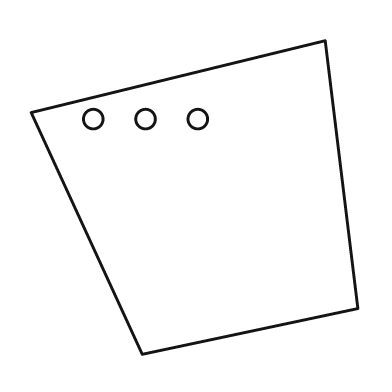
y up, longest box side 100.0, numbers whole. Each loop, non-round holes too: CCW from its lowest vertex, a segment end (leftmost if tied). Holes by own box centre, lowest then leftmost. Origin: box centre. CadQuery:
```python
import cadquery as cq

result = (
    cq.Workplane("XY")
    .moveTo(-16.0, -48.0)
    .lineTo(50.0, -34.0)
    .lineTo(40.0, 48.0)
    .lineTo(-50.0, 26.0)
    .close()
    .moveTo(-31.0, 24.0)
    .circle(3.0)
    .moveTo(-15.0, 24.0)
    .circle(3.0)
    .moveTo(1.0, 24.0)
    .circle(3.0)
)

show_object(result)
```